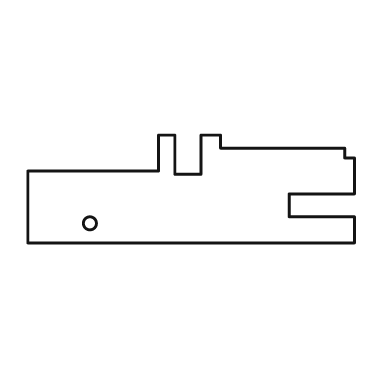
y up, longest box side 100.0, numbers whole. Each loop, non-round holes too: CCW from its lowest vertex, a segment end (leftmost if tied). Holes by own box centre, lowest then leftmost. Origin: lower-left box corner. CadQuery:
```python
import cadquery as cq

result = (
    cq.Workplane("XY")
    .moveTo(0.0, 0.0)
    .lineTo(100.0, 0.0)
    .lineTo(100.0, 8.0)
    .lineTo(80.0, 8.0)
    .lineTo(80.0, 15.0)
    .lineTo(100.0, 15.0)
    .lineTo(100.0, 26.0)
    .lineTo(97.0, 26.0)
    .lineTo(97.0, 29.0)
    .lineTo(59.0, 29.0)
    .lineTo(59.0, 33.0)
    .lineTo(53.0, 33.0)
    .lineTo(53.0, 21.0)
    .lineTo(45.0, 21.0)
    .lineTo(45.0, 33.0)
    .lineTo(40.0, 33.0)
    .lineTo(40.0, 22.0)
    .lineTo(0.0, 22.0)
    .close()
    .moveTo(19.0, 6.0)
    .circle(2.0)
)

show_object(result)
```